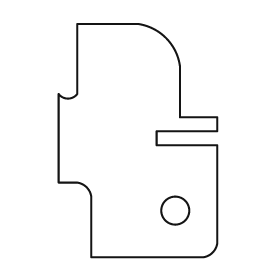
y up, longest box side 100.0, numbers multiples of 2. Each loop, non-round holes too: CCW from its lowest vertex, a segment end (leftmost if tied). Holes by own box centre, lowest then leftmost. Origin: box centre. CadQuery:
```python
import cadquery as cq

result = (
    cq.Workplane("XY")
    .moveTo(-20.0, -50.0)
    .lineTo(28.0, -50.0)
    .threePointArc((32.0, -48.0), (34.0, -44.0))
    .lineTo(34.0, -2.0)
    .lineTo(8.0, -2.0)
    .lineTo(8.0, 4.0)
    .lineTo(34.0, 4.0)
    .lineTo(34.0, 10.0)
    .lineTo(18.0, 10.0)
    .lineTo(18.0, 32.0)
    .threePointArc((12.0, 44.0), (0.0, 50.0))
    .lineTo(-26.0, 50.0)
    .lineTo(-26.0, 20.0)
    .threePointArc((-30.0, 18.0), (-34.0, 20.0))
    .lineTo(-34.0, -18.0)
    .lineTo(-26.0, -18.0)
    .threePointArc((-22.0, -20.0), (-20.0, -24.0))
    .close()
    .moveTo(16.0, -30.0)
    .circle(6.0)
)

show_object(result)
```